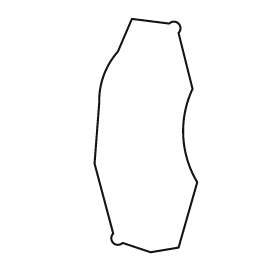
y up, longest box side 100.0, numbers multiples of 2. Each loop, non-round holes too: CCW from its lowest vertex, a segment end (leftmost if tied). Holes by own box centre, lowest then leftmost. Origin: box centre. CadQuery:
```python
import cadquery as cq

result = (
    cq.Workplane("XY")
    .moveTo(2.0, -50.0)
    .lineTo(14.0, -48.0)
    .lineTo(22.0, -20.0)
    .threePointArc((16.0, 0.0), (20.0, 20.0))
    .lineTo(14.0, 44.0)
    .threePointArc((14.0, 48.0), (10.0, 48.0))
    .lineTo(-6.0, 50.0)
    .lineTo(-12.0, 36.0)
    .threePointArc((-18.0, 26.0), (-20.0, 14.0))
    .lineTo(-22.0, -12.0)
    .lineTo(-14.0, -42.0)
    .threePointArc((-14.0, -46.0), (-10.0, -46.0))
    .close()
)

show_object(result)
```